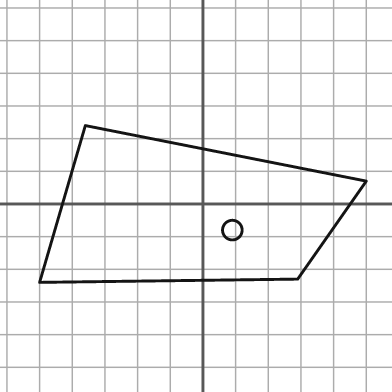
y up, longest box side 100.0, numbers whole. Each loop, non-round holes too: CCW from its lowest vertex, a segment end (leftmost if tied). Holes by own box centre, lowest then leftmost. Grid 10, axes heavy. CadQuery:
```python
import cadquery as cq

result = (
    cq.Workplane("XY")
    .moveTo(-50.0, -24.0)
    .lineTo(29.0, -23.0)
    .lineTo(50.0, 7.0)
    .lineTo(-36.0, 24.0)
    .close()
    .moveTo(9.0, -8.0)
    .circle(3.0)
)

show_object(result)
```